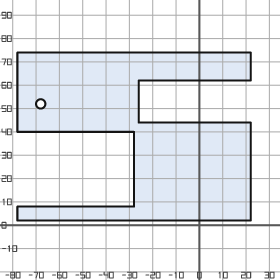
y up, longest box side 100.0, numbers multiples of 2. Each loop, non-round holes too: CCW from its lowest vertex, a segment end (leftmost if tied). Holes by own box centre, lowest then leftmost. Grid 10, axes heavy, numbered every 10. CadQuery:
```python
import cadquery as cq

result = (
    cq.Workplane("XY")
    .moveTo(-78.0, 2.0)
    .lineTo(22.0, 2.0)
    .lineTo(22.0, 44.0)
    .lineTo(-26.0, 44.0)
    .lineTo(-26.0, 62.0)
    .lineTo(22.0, 62.0)
    .lineTo(22.0, 74.0)
    .lineTo(-78.0, 74.0)
    .lineTo(-78.0, 40.0)
    .lineTo(-28.0, 40.0)
    .lineTo(-28.0, 8.0)
    .lineTo(-78.0, 8.0)
    .close()
    .moveTo(-68.0, 52.0)
    .circle(2.0)
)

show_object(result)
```